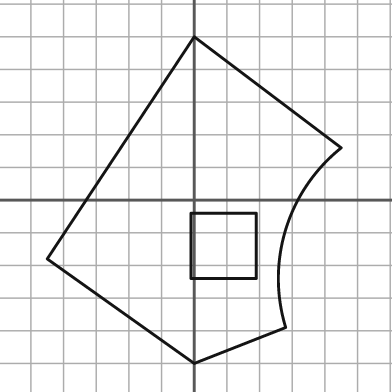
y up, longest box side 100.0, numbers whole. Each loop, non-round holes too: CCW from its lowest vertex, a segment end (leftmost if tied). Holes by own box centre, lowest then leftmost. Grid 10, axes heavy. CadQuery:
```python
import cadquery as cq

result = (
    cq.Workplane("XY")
    .moveTo(0.0, -50.0)
    .lineTo(28.0, -39.0)
    .threePointArc((28.0, -9.0), (45.0, 16.0))
    .lineTo(0.0, 50.0)
    .lineTo(-45.0, -18.0)
    .close()
    .moveTo(-1.0, -24.0)
    .lineTo(19.0, -24.0)
    .lineTo(19.0, -4.0)
    .lineTo(-1.0, -4.0)
    .close()
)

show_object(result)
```